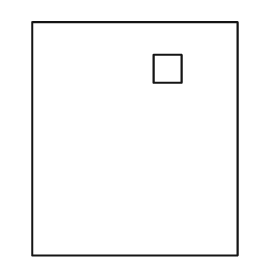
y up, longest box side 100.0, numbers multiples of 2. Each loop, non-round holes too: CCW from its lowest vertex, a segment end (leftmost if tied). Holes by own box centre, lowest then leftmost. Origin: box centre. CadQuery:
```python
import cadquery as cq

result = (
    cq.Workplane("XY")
    .moveTo(-44.0, -50.0)
    .lineTo(44.0, -50.0)
    .lineTo(44.0, 50.0)
    .lineTo(-44.0, 50.0)
    .close()
    .moveTo(8.0, 24.0)
    .lineTo(20.0, 24.0)
    .lineTo(20.0, 36.0)
    .lineTo(8.0, 36.0)
    .close()
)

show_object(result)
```